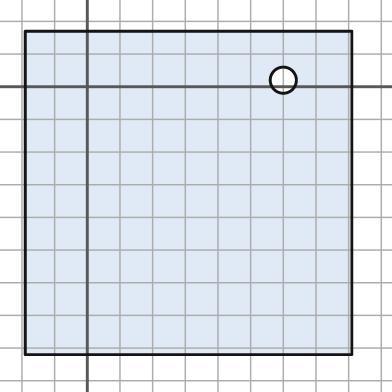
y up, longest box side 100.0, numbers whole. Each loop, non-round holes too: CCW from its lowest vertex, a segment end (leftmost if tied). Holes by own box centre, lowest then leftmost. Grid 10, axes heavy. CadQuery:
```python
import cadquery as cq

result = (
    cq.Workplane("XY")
    .moveTo(-19.0, -82.0)
    .lineTo(81.0, -82.0)
    .lineTo(81.0, 17.0)
    .lineTo(-19.0, 17.0)
    .close()
    .moveTo(60.0, 2.0)
    .circle(4.0)
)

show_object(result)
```